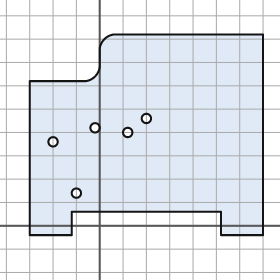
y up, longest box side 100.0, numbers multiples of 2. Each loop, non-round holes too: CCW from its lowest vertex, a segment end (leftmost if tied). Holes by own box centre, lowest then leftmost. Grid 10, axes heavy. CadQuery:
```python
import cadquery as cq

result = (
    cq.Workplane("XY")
    .moveTo(-30.0, -4.0)
    .lineTo(-12.0, -4.0)
    .lineTo(-12.0, 6.0)
    .lineTo(52.0, 6.0)
    .lineTo(52.0, -4.0)
    .lineTo(70.0, -4.0)
    .lineTo(70.0, 82.0)
    .lineTo(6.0, 82.0)
    .threePointArc((2.0, 80.0), (0.0, 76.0))
    .lineTo(0.0, 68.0)
    .threePointArc((-2.0, 64.0), (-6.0, 62.0))
    .lineTo(-30.0, 62.0)
    .close()
    .moveTo(-10.0, 14.0)
    .circle(2.0)
    .moveTo(-20.0, 36.0)
    .circle(2.0)
    .moveTo(12.0, 40.0)
    .circle(2.0)
    .moveTo(-2.0, 42.0)
    .circle(2.0)
    .moveTo(20.0, 46.0)
    .circle(2.0)
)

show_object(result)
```